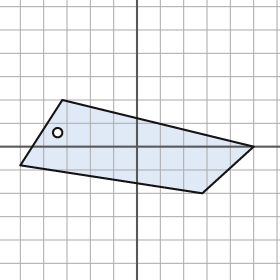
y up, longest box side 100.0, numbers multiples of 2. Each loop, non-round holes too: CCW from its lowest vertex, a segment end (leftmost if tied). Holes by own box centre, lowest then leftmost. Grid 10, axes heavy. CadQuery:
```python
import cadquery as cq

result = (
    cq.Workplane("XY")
    .moveTo(28.0, -20.0)
    .lineTo(50.0, 0.0)
    .lineTo(-32.0, 20.0)
    .lineTo(-50.0, -8.0)
    .close()
    .moveTo(-34.0, 6.0)
    .circle(2.0)
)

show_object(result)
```